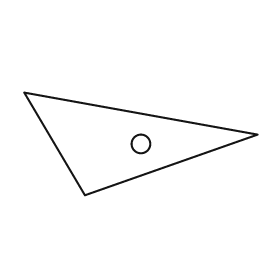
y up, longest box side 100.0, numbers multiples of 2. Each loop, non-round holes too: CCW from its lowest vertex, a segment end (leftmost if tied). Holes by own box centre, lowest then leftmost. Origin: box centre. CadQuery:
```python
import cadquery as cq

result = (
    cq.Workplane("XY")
    .moveTo(-24.0, -22.0)
    .lineTo(50.0, 4.0)
    .lineTo(-50.0, 22.0)
    .close()
    .moveTo(0.0, 0.0)
    .circle(4.0)
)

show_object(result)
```